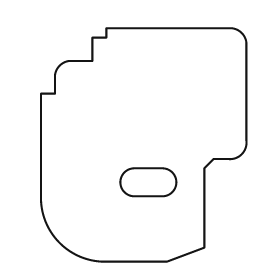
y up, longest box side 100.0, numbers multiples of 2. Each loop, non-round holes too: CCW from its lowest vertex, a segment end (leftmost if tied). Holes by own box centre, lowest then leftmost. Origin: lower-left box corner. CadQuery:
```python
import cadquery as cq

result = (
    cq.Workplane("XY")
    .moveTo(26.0, 0.0)
    .lineTo(54.0, 0.0)
    .lineTo(70.0, 6.0)
    .lineTo(70.0, 40.0)
    .lineTo(74.0, 44.0)
    .lineTo(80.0, 44.0)
    .threePointArc((86.0, 46.0), (88.0, 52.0))
    .lineTo(88.0, 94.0)
    .threePointArc((86.0, 98.0), (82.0, 100.0))
    .lineTo(28.0, 100.0)
    .lineTo(28.0, 96.0)
    .lineTo(22.0, 96.0)
    .lineTo(22.0, 86.0)
    .lineTo(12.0, 86.0)
    .threePointArc((8.0, 84.0), (6.0, 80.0))
    .lineTo(6.0, 72.0)
    .lineTo(0.0, 72.0)
    .lineTo(0.0, 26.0)
    .threePointArc((8.0, 8.0), (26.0, 0.0))
    .close()
    .moveTo(40.0, 28.0)
    .lineTo(52.0, 28.0)
    .threePointArc((58.0, 34.0), (52.0, 40.0))
    .lineTo(40.0, 40.0)
    .threePointArc((34.0, 34.0), (40.0, 28.0))
    .close()
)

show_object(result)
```